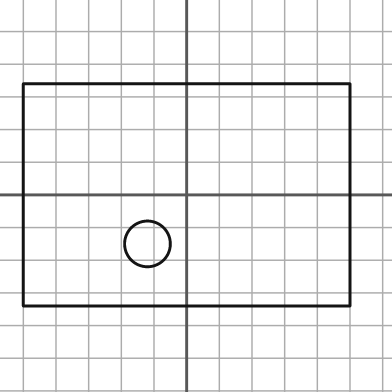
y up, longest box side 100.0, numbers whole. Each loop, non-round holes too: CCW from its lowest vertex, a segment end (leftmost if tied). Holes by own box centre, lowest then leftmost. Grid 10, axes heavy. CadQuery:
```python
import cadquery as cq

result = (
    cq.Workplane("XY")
    .moveTo(-50.0, -34.0)
    .lineTo(50.0, -34.0)
    .lineTo(50.0, 34.0)
    .lineTo(-50.0, 34.0)
    .close()
    .moveTo(-12.0, -15.0)
    .circle(7.0)
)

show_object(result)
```